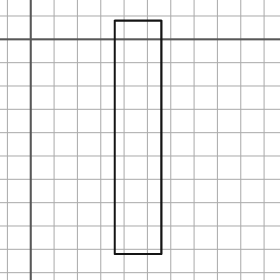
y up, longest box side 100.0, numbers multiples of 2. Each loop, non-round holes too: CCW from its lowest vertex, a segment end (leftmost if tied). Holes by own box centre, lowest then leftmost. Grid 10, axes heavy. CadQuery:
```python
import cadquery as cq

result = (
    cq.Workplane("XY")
    .moveTo(36.0, -92.0)
    .lineTo(56.0, -92.0)
    .lineTo(56.0, 8.0)
    .lineTo(36.0, 8.0)
    .close()
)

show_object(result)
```